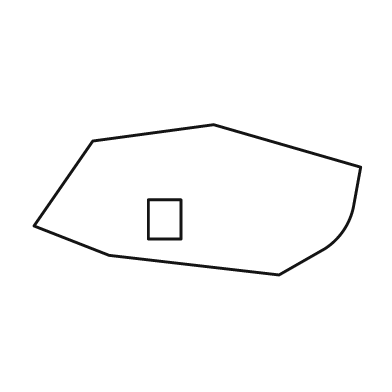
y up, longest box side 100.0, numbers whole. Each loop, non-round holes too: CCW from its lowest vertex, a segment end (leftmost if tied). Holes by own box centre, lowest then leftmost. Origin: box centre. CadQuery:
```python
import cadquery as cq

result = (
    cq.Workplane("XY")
    .moveTo(25.0, -23.0)
    .lineTo(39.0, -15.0)
    .threePointArc((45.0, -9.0), (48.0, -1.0))
    .lineTo(50.0, 10.0)
    .lineTo(5.0, 23.0)
    .lineTo(-32.0, 18.0)
    .lineTo(-50.0, -8.0)
    .lineTo(-27.0, -17.0)
    .close()
    .moveTo(-15.0, -12.0)
    .lineTo(-5.0, -12.0)
    .lineTo(-5.0, 0.0)
    .lineTo(-15.0, 0.0)
    .close()
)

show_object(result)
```